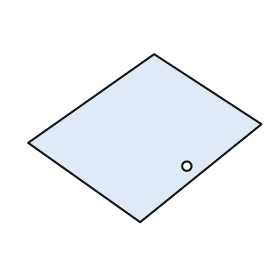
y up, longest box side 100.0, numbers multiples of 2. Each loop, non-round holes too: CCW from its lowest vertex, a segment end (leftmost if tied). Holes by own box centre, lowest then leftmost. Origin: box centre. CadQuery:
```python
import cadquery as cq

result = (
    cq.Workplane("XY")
    .moveTo(-2.0, -36.0)
    .lineTo(50.0, 6.0)
    .lineTo(4.0, 36.0)
    .lineTo(-50.0, -2.0)
    .close()
    .moveTo(18.0, -12.0)
    .circle(2.0)
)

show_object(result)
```